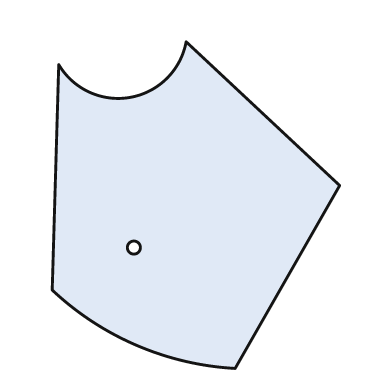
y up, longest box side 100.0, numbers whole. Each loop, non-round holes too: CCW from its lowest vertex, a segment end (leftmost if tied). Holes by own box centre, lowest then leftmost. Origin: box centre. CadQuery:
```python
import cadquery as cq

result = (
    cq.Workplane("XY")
    .moveTo(12.0, -50.0)
    .lineTo(44.0, 6.0)
    .lineTo(-3.0, 50.0)
    .threePointArc((-20.0, 33.0), (-42.0, 43.0))
    .lineTo(-44.0, -26.0)
    .threePointArc((-18.0, -43.0), (12.0, -50.0))
    .close()
    .moveTo(-19.0, -13.0)
    .circle(2.0)
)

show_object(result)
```